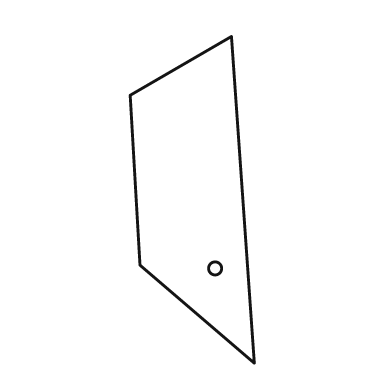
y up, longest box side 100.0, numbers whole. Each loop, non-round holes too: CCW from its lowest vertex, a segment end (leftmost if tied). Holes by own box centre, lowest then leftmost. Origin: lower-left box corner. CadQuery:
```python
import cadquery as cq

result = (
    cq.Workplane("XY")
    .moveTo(38.0, 0.0)
    .lineTo(31.0, 100.0)
    .lineTo(0.0, 82.0)
    .lineTo(3.0, 30.0)
    .close()
    .moveTo(26.0, 29.0)
    .circle(2.0)
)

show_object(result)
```